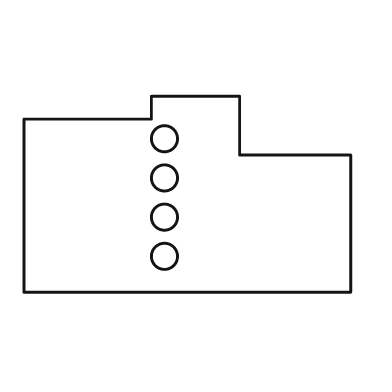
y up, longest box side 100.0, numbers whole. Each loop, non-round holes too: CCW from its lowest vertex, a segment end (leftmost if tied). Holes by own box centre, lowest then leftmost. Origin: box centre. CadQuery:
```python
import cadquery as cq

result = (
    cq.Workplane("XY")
    .moveTo(-50.0, -30.0)
    .lineTo(50.0, -30.0)
    .lineTo(50.0, 12.0)
    .lineTo(16.0, 12.0)
    .lineTo(16.0, 30.0)
    .lineTo(-11.0, 30.0)
    .lineTo(-11.0, 23.0)
    .lineTo(-50.0, 23.0)
    .close()
    .moveTo(-7.0, -19.0)
    .circle(4.0)
    .moveTo(-7.0, -7.0)
    .circle(4.0)
    .moveTo(-7.0, 5.0)
    .circle(4.0)
    .moveTo(-7.0, 17.0)
    .circle(4.0)
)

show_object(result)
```